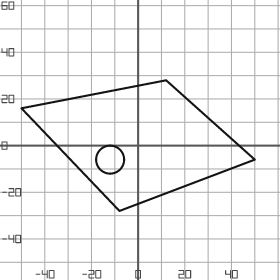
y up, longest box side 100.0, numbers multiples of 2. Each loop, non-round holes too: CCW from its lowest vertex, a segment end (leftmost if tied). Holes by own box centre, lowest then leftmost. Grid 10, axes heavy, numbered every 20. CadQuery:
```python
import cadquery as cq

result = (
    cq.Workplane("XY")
    .moveTo(-8.0, -28.0)
    .lineTo(50.0, -6.0)
    .lineTo(12.0, 28.0)
    .lineTo(-50.0, 16.0)
    .close()
    .moveTo(-12.0, -6.0)
    .circle(6.0)
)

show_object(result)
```